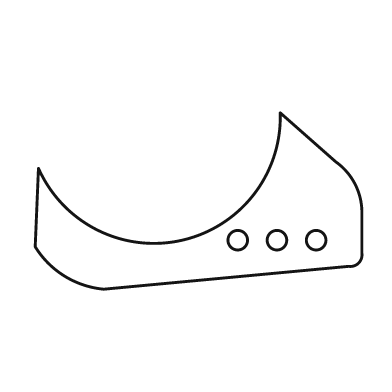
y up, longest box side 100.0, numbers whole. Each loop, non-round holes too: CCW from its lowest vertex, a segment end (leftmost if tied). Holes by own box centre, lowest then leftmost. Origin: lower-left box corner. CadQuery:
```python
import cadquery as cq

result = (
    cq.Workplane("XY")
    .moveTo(21.0, 0.0)
    .lineTo(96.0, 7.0)
    .threePointArc((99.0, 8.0), (100.0, 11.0))
    .lineTo(100.0, 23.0)
    .threePointArc((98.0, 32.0), (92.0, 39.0))
    .lineTo(75.0, 54.0)
    .threePointArc((45.0, 15.0), (1.0, 37.0))
    .lineTo(0.0, 13.0)
    .threePointArc((9.0, 4.0), (21.0, 0.0))
    .close()
    .moveTo(62.0, 15.0)
    .circle(3.0)
    .moveTo(74.0, 15.0)
    .circle(3.0)
    .moveTo(86.0, 15.0)
    .circle(3.0)
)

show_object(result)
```